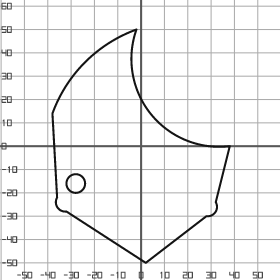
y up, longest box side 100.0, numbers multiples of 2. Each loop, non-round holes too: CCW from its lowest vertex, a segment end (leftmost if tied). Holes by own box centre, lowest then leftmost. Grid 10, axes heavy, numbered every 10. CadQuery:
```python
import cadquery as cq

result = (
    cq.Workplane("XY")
    .moveTo(2.0, -50.0)
    .lineTo(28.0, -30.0)
    .threePointArc((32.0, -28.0), (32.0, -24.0))
    .lineTo(38.0, 0.0)
    .threePointArc((4.0, 14.0), (-2.0, 50.0))
    .threePointArc((-24.0, 36.0), (-38.0, 14.0))
    .lineTo(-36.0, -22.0)
    .threePointArc((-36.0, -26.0), (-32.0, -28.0))
    .close()
    .moveTo(-28.0, -16.0)
    .circle(4.0)
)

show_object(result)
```